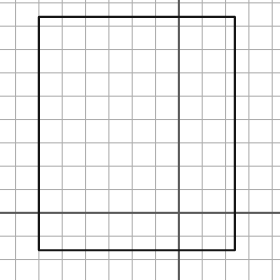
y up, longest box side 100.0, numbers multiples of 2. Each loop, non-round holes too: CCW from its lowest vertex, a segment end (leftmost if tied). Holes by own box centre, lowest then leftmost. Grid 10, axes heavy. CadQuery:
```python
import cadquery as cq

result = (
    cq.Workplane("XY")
    .moveTo(-60.0, -16.0)
    .lineTo(24.0, -16.0)
    .lineTo(24.0, 84.0)
    .lineTo(-60.0, 84.0)
    .close()
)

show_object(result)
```